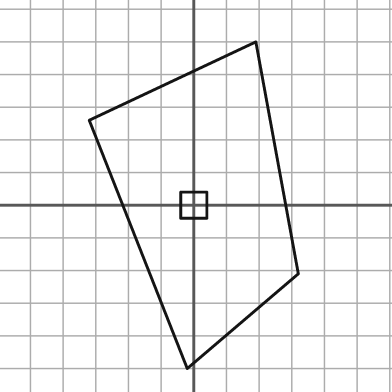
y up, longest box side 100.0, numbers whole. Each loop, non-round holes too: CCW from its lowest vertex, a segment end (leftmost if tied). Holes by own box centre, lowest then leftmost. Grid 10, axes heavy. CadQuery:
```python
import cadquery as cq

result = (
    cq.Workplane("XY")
    .moveTo(-2.0, -50.0)
    .lineTo(32.0, -21.0)
    .lineTo(19.0, 50.0)
    .lineTo(-32.0, 26.0)
    .close()
    .moveTo(-4.0, -4.0)
    .lineTo(4.0, -4.0)
    .lineTo(4.0, 4.0)
    .lineTo(-4.0, 4.0)
    .close()
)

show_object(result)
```